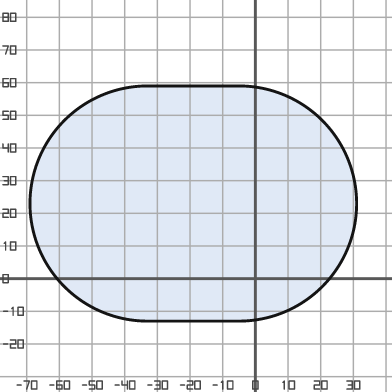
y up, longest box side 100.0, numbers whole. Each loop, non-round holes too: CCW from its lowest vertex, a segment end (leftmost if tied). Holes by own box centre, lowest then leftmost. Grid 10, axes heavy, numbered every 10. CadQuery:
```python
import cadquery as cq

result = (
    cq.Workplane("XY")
    .moveTo(-33.0, -13.0)
    .lineTo(-5.0, -13.0)
    .threePointArc((31.0, 23.0), (-5.0, 59.0))
    .lineTo(-33.0, 59.0)
    .threePointArc((-69.0, 23.0), (-33.0, -13.0))
    .close()
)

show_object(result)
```